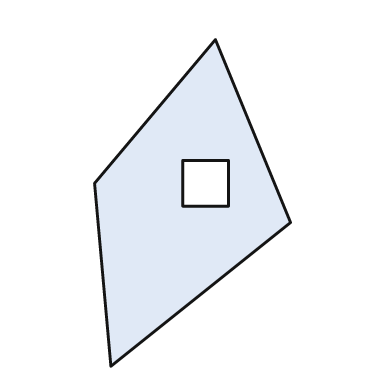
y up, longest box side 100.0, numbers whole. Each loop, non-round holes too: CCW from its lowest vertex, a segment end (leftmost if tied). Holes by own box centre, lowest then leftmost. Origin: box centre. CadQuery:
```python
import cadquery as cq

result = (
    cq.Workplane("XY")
    .moveTo(-25.0, -50.0)
    .lineTo(30.0, -6.0)
    .lineTo(7.0, 50.0)
    .lineTo(-30.0, 6.0)
    .close()
    .moveTo(-3.0, -1.0)
    .lineTo(11.0, -1.0)
    .lineTo(11.0, 13.0)
    .lineTo(-3.0, 13.0)
    .close()
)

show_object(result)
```